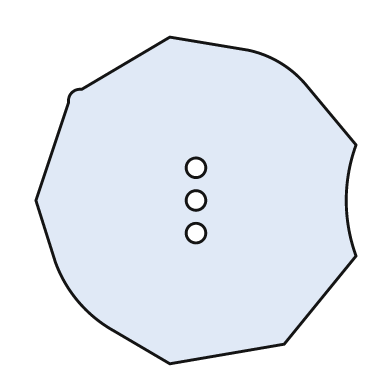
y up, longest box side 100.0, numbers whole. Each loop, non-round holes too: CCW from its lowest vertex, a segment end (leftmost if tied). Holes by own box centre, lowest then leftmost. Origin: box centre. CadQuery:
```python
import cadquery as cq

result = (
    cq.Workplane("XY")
    .moveTo(-8.0, -50.0)
    .lineTo(27.0, -44.0)
    .lineTo(49.0, -17.0)
    .threePointArc((46.0, 0.0), (49.0, 17.0))
    .lineTo(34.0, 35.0)
    .threePointArc((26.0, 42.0), (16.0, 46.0))
    .lineTo(-8.0, 50.0)
    .lineTo(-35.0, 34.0)
    .threePointArc((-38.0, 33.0), (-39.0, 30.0))
    .lineTo(-49.0, 0.0)
    .lineTo(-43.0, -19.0)
    .threePointArc((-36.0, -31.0), (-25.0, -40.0))
    .close()
    .moveTo(0.0, -10.0)
    .circle(3.0)
    .moveTo(0.0, 0.0)
    .circle(3.0)
    .moveTo(0.0, 10.0)
    .circle(3.0)
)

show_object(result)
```